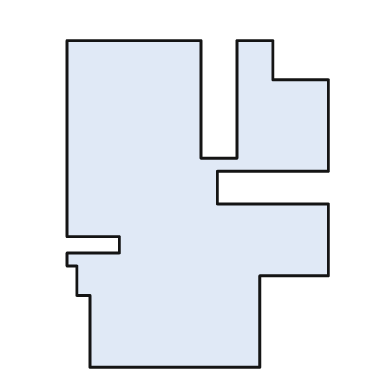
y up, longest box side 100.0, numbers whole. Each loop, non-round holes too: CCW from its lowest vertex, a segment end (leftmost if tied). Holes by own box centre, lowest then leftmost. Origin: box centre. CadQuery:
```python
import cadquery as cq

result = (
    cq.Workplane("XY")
    .moveTo(-33.0, -50.0)
    .lineTo(19.0, -50.0)
    .lineTo(19.0, -22.0)
    .lineTo(40.0, -22.0)
    .lineTo(40.0, 0.0)
    .lineTo(6.0, 0.0)
    .lineTo(6.0, 10.0)
    .lineTo(40.0, 10.0)
    .lineTo(40.0, 38.0)
    .lineTo(23.0, 38.0)
    .lineTo(23.0, 50.0)
    .lineTo(12.0, 50.0)
    .lineTo(12.0, 14.0)
    .lineTo(1.0, 14.0)
    .lineTo(1.0, 50.0)
    .lineTo(-40.0, 50.0)
    .lineTo(-40.0, -10.0)
    .lineTo(-24.0, -10.0)
    .lineTo(-24.0, -15.0)
    .lineTo(-40.0, -15.0)
    .lineTo(-40.0, -19.0)
    .lineTo(-37.0, -19.0)
    .lineTo(-37.0, -28.0)
    .lineTo(-33.0, -28.0)
    .close()
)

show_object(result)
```